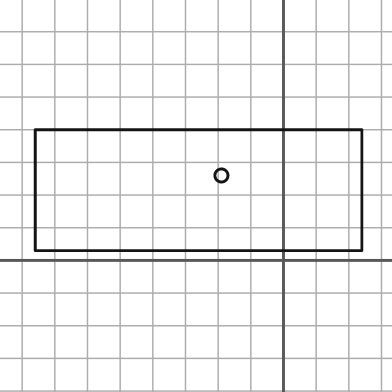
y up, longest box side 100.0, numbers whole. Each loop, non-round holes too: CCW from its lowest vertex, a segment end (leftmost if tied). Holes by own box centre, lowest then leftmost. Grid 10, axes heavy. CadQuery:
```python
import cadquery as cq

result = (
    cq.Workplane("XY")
    .moveTo(-76.0, 3.0)
    .lineTo(24.0, 3.0)
    .lineTo(24.0, 40.0)
    .lineTo(-76.0, 40.0)
    .close()
    .moveTo(-19.0, 26.0)
    .circle(2.0)
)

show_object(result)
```